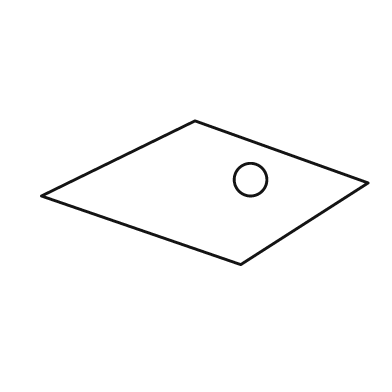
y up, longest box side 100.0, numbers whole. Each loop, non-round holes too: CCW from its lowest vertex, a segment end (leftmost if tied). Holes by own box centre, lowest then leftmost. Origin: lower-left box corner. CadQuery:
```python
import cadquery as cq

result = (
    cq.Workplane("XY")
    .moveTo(61.0, 0.0)
    .lineTo(100.0, 25.0)
    .lineTo(47.0, 44.0)
    .lineTo(0.0, 21.0)
    .close()
    .moveTo(64.0, 26.0)
    .circle(5.0)
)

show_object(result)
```